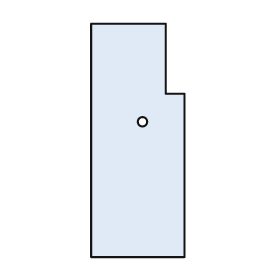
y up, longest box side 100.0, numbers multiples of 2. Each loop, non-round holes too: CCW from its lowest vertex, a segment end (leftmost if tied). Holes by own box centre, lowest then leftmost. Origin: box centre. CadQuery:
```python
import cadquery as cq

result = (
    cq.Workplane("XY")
    .moveTo(-20.0, -50.0)
    .lineTo(20.0, -50.0)
    .lineTo(20.0, 20.0)
    .lineTo(12.0, 20.0)
    .lineTo(12.0, 50.0)
    .lineTo(-20.0, 50.0)
    .close()
    .moveTo(2.0, 8.0)
    .circle(2.0)
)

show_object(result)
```